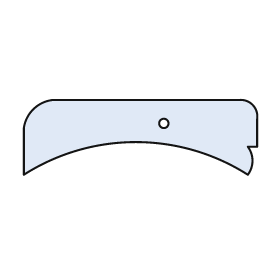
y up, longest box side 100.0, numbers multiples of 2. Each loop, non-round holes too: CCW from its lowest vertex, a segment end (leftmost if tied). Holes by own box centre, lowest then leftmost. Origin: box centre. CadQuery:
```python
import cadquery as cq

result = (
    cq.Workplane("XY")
    .moveTo(-50.0, -16.0)
    .threePointArc((-2.0, -2.0), (46.0, -16.0))
    .threePointArc((48.0, -10.0), (46.0, -4.0))
    .lineTo(50.0, -4.0)
    .lineTo(50.0, 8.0)
    .threePointArc((48.0, 14.0), (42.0, 16.0))
    .lineTo(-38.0, 16.0)
    .threePointArc((-46.0, 12.0), (-50.0, 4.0))
    .close()
    .moveTo(10.0, 6.0)
    .circle(2.0)
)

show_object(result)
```